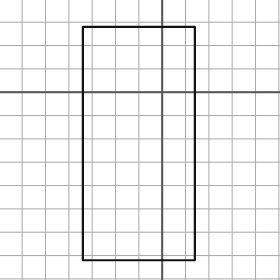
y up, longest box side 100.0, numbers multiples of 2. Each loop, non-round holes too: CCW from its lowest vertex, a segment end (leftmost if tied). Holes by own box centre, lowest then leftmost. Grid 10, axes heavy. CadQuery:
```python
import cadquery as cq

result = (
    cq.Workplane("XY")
    .moveTo(-34.0, -72.0)
    .lineTo(14.0, -72.0)
    .lineTo(14.0, 28.0)
    .lineTo(-34.0, 28.0)
    .close()
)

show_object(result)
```